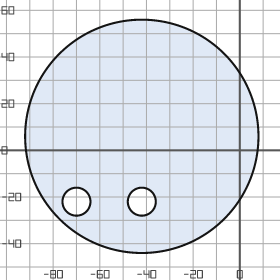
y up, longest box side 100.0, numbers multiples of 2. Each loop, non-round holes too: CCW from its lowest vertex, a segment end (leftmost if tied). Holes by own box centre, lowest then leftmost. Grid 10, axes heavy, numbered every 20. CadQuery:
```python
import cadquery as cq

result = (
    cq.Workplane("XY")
    .moveTo(-42.0, 6.0)
    .circle(50.0)
    .moveTo(-70.0, -22.0)
    .circle(6.0)
    .moveTo(-42.0, -22.0)
    .circle(6.0)
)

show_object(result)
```